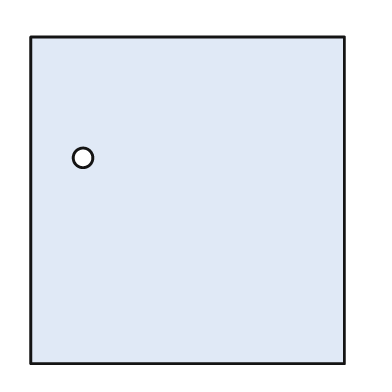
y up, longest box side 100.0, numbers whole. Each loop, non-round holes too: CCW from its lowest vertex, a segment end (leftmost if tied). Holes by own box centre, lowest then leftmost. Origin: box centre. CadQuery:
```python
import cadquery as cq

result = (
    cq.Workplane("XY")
    .moveTo(-48.0, -50.0)
    .lineTo(48.0, -50.0)
    .lineTo(48.0, 50.0)
    .lineTo(-48.0, 50.0)
    .close()
    .moveTo(-32.0, 13.0)
    .circle(3.0)
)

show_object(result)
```